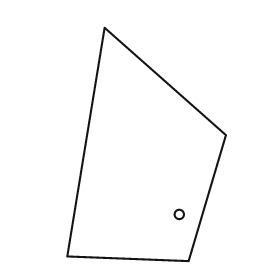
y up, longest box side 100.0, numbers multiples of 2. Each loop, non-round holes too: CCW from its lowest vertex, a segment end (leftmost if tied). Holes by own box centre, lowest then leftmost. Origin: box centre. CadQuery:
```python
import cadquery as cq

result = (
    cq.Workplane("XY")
    .moveTo(18.0, -50.0)
    .lineTo(34.0, 4.0)
    .lineTo(-18.0, 50.0)
    .lineTo(-34.0, -48.0)
    .close()
    .moveTo(14.0, -30.0)
    .circle(2.0)
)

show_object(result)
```